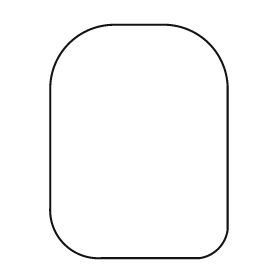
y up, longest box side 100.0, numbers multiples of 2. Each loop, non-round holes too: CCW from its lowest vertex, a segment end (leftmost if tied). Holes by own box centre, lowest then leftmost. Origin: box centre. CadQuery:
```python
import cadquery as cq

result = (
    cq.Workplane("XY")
    .moveTo(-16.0, -50.0)
    .lineTo(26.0, -50.0)
    .threePointArc((34.0, -46.0), (38.0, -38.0))
    .lineTo(38.0, 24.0)
    .threePointArc((30.0, 42.0), (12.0, 50.0))
    .lineTo(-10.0, 50.0)
    .threePointArc((-30.0, 42.0), (-38.0, 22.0))
    .lineTo(-38.0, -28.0)
    .threePointArc((-32.0, -44.0), (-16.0, -50.0))
    .close()
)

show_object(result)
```